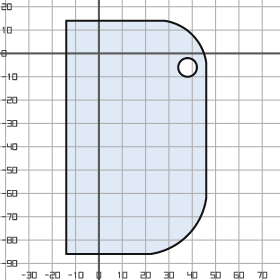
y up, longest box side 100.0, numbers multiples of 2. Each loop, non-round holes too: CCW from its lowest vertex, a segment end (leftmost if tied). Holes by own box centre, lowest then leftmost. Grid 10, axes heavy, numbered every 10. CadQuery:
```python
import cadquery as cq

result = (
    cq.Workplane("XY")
    .moveTo(-14.0, -86.0)
    .lineTo(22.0, -86.0)
    .threePointArc((38.0, -78.0), (46.0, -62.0))
    .lineTo(46.0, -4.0)
    .threePointArc((40.0, 8.0), (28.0, 14.0))
    .lineTo(-14.0, 14.0)
    .close()
    .moveTo(38.0, -6.0)
    .circle(4.0)
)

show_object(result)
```